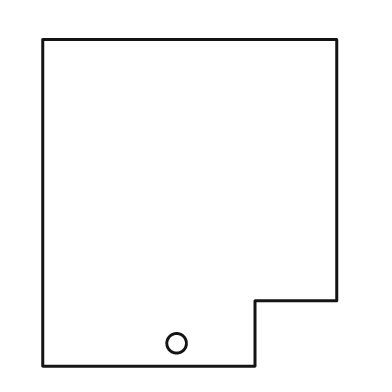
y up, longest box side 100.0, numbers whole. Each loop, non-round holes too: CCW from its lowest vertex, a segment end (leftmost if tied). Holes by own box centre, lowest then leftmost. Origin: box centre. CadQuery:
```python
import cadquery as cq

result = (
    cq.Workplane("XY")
    .moveTo(-45.0, -50.0)
    .lineTo(20.0, -50.0)
    .lineTo(20.0, -30.0)
    .lineTo(45.0, -30.0)
    .lineTo(45.0, 50.0)
    .lineTo(-45.0, 50.0)
    .close()
    .moveTo(-4.0, -43.0)
    .circle(3.0)
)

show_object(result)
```